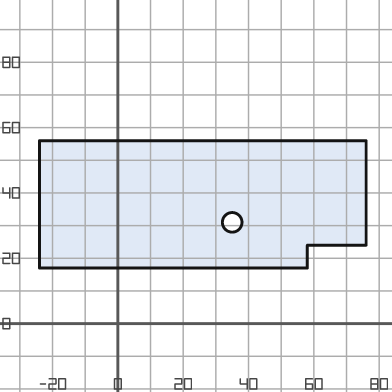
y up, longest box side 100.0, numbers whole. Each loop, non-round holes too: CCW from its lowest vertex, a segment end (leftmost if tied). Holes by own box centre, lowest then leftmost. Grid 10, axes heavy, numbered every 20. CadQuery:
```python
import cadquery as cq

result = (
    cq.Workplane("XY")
    .moveTo(-24.0, 17.0)
    .lineTo(58.0, 17.0)
    .lineTo(58.0, 24.0)
    .lineTo(76.0, 24.0)
    .lineTo(76.0, 56.0)
    .lineTo(-24.0, 56.0)
    .close()
    .moveTo(35.0, 31.0)
    .circle(3.0)
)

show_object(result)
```